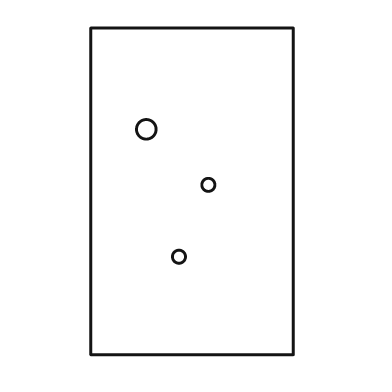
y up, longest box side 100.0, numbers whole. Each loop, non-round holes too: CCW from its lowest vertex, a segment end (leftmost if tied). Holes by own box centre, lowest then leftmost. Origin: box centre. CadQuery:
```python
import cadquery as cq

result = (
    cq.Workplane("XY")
    .moveTo(-31.0, -50.0)
    .lineTo(31.0, -50.0)
    .lineTo(31.0, 50.0)
    .lineTo(-31.0, 50.0)
    .close()
    .moveTo(-4.0, -20.0)
    .circle(2.0)
    .moveTo(5.0, 2.0)
    .circle(2.0)
    .moveTo(-14.0, 19.0)
    .circle(3.0)
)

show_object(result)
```